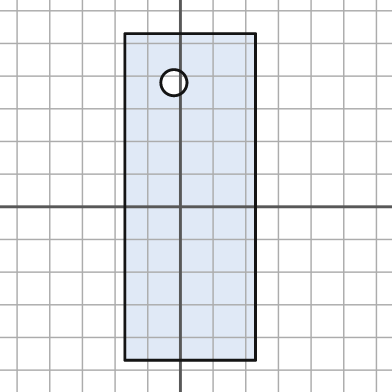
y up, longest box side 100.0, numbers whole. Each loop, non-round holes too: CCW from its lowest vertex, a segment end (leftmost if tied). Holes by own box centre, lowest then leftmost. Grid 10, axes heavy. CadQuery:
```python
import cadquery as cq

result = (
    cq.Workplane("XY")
    .moveTo(-17.0, -47.0)
    .lineTo(23.0, -47.0)
    .lineTo(23.0, 53.0)
    .lineTo(-17.0, 53.0)
    .close()
    .moveTo(-2.0, 38.0)
    .circle(4.0)
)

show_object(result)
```